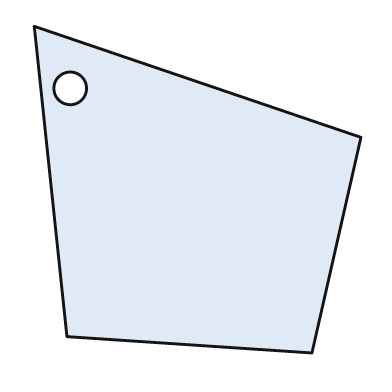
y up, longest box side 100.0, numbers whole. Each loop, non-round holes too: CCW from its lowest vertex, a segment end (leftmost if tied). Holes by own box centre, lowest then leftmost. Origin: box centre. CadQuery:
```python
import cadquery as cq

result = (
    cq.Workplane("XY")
    .moveTo(35.0, -50.0)
    .lineTo(50.0, 16.0)
    .lineTo(-50.0, 50.0)
    .lineTo(-40.0, -45.0)
    .close()
    .moveTo(-39.0, 31.0)
    .circle(5.0)
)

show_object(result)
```